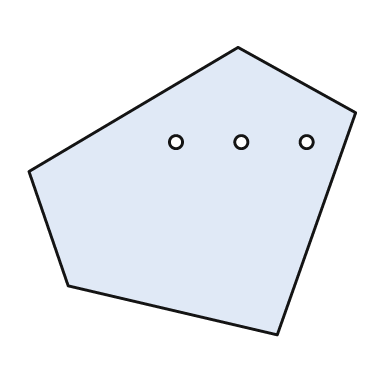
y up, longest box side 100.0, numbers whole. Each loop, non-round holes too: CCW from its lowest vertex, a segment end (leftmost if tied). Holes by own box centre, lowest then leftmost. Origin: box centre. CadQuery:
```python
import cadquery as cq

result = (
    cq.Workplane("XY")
    .moveTo(26.0, -44.0)
    .lineTo(50.0, 24.0)
    .lineTo(14.0, 44.0)
    .lineTo(-50.0, 6.0)
    .lineTo(-38.0, -29.0)
    .close()
    .moveTo(-5.0, 15.0)
    .circle(2.0)
    .moveTo(15.0, 15.0)
    .circle(2.0)
    .moveTo(35.0, 15.0)
    .circle(2.0)
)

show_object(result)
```